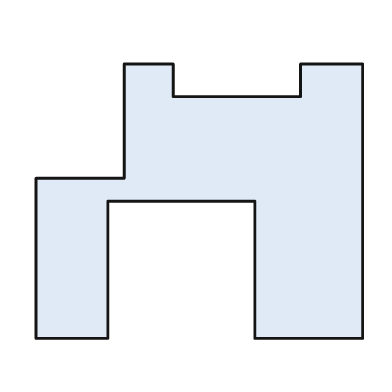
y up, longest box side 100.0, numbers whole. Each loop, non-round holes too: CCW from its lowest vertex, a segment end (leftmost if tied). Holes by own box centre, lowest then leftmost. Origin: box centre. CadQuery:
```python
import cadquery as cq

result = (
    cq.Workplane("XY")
    .moveTo(-50.0, -42.0)
    .lineTo(-28.0, -42.0)
    .lineTo(-28.0, 0.0)
    .lineTo(17.0, 0.0)
    .lineTo(17.0, -42.0)
    .lineTo(50.0, -42.0)
    .lineTo(50.0, 42.0)
    .lineTo(31.0, 42.0)
    .lineTo(31.0, 32.0)
    .lineTo(-8.0, 32.0)
    .lineTo(-8.0, 42.0)
    .lineTo(-23.0, 42.0)
    .lineTo(-23.0, 7.0)
    .lineTo(-50.0, 7.0)
    .close()
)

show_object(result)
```